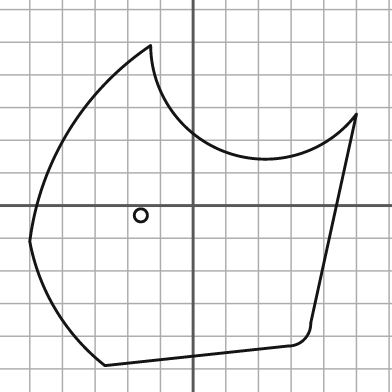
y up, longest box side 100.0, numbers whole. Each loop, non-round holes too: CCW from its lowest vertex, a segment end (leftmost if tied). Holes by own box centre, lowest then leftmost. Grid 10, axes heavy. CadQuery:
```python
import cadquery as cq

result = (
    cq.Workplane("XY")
    .moveTo(-27.0, -49.0)
    .lineTo(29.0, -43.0)
    .threePointArc((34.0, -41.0), (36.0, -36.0))
    .lineTo(50.0, 28.0)
    .threePointArc((11.0, 16.0), (-13.0, 49.0))
    .threePointArc((-38.0, 23.0), (-50.0, -11.0))
    .threePointArc((-42.0, -32.0), (-27.0, -49.0))
    .close()
    .moveTo(-16.0, -3.0)
    .circle(2.0)
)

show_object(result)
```